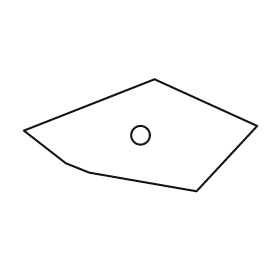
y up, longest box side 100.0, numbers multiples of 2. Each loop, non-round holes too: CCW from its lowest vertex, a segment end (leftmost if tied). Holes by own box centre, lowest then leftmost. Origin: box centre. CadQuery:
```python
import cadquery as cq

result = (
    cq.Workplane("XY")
    .moveTo(24.0, -24.0)
    .lineTo(50.0, 4.0)
    .lineTo(6.0, 24.0)
    .lineTo(-50.0, 2.0)
    .lineTo(-32.0, -12.0)
    .lineTo(-22.0, -16.0)
    .close()
    .moveTo(0.0, 0.0)
    .circle(4.0)
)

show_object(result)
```